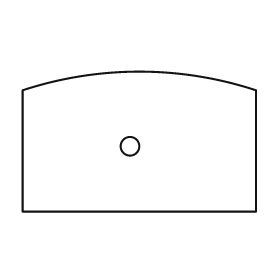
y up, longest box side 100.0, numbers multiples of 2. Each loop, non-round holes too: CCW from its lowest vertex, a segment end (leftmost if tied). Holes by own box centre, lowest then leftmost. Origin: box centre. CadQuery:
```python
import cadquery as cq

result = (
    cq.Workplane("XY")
    .moveTo(-50.0, -30.0)
    .lineTo(50.0, -30.0)
    .lineTo(50.0, 22.0)
    .threePointArc((0.0, 30.0), (-50.0, 22.0))
    .close()
    .moveTo(-4.0, -2.0)
    .circle(4.0)
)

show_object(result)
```